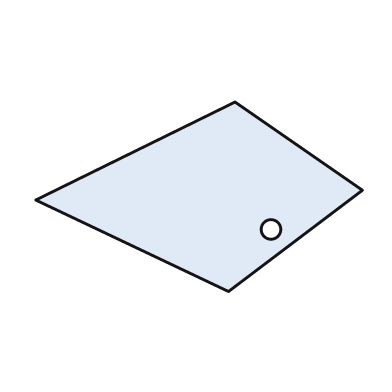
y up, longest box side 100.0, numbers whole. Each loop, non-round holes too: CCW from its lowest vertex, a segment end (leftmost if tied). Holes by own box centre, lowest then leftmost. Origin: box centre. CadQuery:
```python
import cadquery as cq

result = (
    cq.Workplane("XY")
    .moveTo(9.0, -29.0)
    .lineTo(50.0, 2.0)
    .lineTo(11.0, 29.0)
    .lineTo(-50.0, -1.0)
    .close()
    .moveTo(22.0, -10.0)
    .circle(3.0)
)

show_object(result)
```